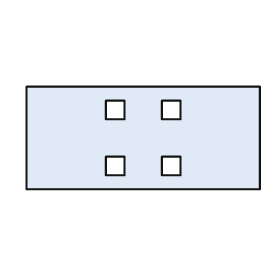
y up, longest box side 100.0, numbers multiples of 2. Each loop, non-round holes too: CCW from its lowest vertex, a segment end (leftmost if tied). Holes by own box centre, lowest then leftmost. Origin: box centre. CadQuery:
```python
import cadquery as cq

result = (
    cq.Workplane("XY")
    .moveTo(-50.0, -22.0)
    .lineTo(50.0, -22.0)
    .lineTo(50.0, 22.0)
    .lineTo(-50.0, 22.0)
    .close()
    .moveTo(-16.0, -16.0)
    .lineTo(-8.0, -16.0)
    .lineTo(-8.0, -8.0)
    .lineTo(-16.0, -8.0)
    .close()
    .moveTo(8.0, -16.0)
    .lineTo(16.0, -16.0)
    .lineTo(16.0, -8.0)
    .lineTo(8.0, -8.0)
    .close()
    .moveTo(-16.0, 8.0)
    .lineTo(-8.0, 8.0)
    .lineTo(-8.0, 16.0)
    .lineTo(-16.0, 16.0)
    .close()
    .moveTo(8.0, 8.0)
    .lineTo(16.0, 8.0)
    .lineTo(16.0, 16.0)
    .lineTo(8.0, 16.0)
    .close()
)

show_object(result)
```